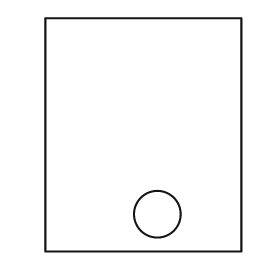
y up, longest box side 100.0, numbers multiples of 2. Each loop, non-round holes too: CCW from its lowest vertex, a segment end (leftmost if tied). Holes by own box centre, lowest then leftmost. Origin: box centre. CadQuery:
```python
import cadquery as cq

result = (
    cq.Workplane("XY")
    .moveTo(-42.0, -50.0)
    .lineTo(42.0, -50.0)
    .lineTo(42.0, 50.0)
    .lineTo(-42.0, 50.0)
    .close()
    .moveTo(6.0, -34.0)
    .circle(10.0)
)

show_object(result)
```